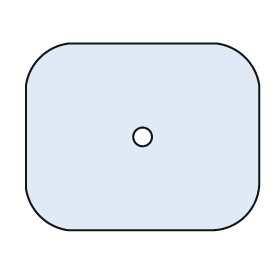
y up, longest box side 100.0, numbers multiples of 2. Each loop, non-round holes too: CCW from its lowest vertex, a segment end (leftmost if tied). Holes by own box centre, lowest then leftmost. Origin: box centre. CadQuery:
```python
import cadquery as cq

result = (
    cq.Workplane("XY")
    .moveTo(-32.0, -40.0)
    .lineTo(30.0, -40.0)
    .threePointArc((44.0, -34.0), (50.0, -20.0))
    .lineTo(50.0, 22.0)
    .threePointArc((44.0, 34.0), (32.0, 40.0))
    .lineTo(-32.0, 40.0)
    .threePointArc((-44.0, 34.0), (-50.0, 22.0))
    .lineTo(-50.0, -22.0)
    .threePointArc((-44.0, -34.0), (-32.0, -40.0))
    .close()
    .moveTo(0.0, 0.0)
    .circle(4.0)
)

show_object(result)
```